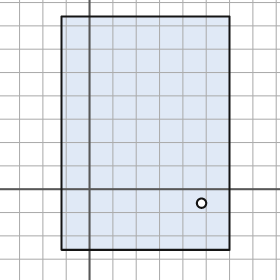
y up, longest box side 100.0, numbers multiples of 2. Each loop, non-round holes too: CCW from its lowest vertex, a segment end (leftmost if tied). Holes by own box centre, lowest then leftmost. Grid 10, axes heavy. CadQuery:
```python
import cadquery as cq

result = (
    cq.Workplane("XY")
    .moveTo(-12.0, -26.0)
    .lineTo(60.0, -26.0)
    .lineTo(60.0, 74.0)
    .lineTo(-12.0, 74.0)
    .close()
    .moveTo(48.0, -6.0)
    .circle(2.0)
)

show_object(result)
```